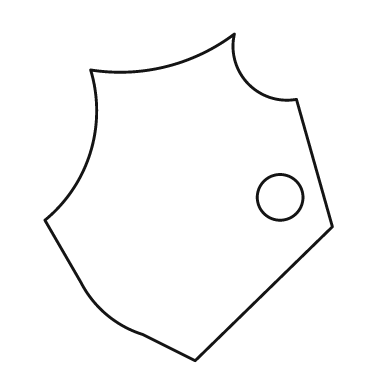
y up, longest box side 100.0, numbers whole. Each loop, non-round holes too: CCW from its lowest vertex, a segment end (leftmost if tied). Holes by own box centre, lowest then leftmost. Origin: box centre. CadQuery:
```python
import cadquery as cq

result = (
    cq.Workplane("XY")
    .moveTo(2.0, -50.0)
    .lineTo(44.0, -9.0)
    .lineTo(33.0, 30.0)
    .threePointArc((18.0, 35.0), (14.0, 50.0))
    .threePointArc((-7.0, 40.0), (-30.0, 39.0))
    .threePointArc((-30.0, 14.0), (-44.0, -7.0))
    .lineTo(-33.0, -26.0)
    .threePointArc((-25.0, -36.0), (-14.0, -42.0))
    .close()
    .moveTo(28.0, 0.0)
    .circle(7.0)
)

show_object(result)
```